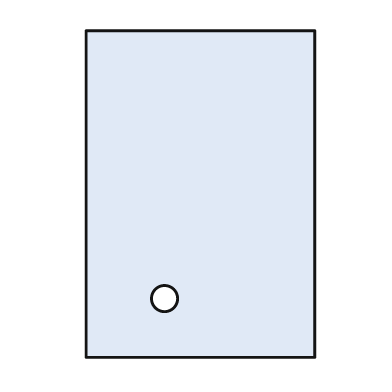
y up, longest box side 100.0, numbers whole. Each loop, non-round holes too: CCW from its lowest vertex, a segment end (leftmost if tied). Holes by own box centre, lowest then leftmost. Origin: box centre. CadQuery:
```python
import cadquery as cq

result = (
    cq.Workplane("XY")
    .moveTo(-35.0, -50.0)
    .lineTo(35.0, -50.0)
    .lineTo(35.0, 50.0)
    .lineTo(-35.0, 50.0)
    .close()
    .moveTo(-11.0, -32.0)
    .circle(4.0)
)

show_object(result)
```